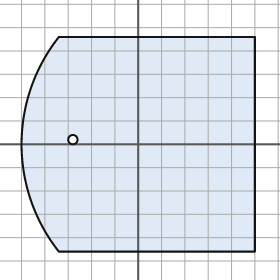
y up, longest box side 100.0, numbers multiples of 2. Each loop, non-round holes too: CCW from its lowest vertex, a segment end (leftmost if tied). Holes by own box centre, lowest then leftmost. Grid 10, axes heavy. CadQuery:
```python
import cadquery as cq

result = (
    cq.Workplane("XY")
    .moveTo(-34.0, -46.0)
    .lineTo(50.0, -46.0)
    .lineTo(50.0, 46.0)
    .lineTo(-34.0, 46.0)
    .threePointArc((-50.0, 0.0), (-34.0, -46.0))
    .close()
    .moveTo(-28.0, 2.0)
    .circle(2.0)
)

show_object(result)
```